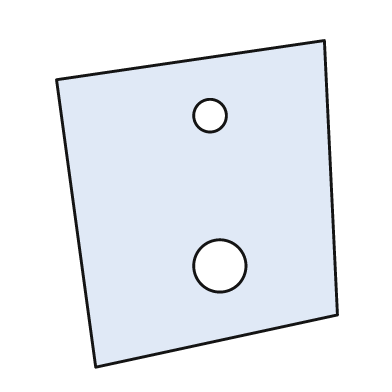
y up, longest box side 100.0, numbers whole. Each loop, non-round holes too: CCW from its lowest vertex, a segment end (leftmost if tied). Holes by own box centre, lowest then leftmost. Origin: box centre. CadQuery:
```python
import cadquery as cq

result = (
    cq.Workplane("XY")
    .moveTo(-31.0, -50.0)
    .lineTo(43.0, -34.0)
    .lineTo(39.0, 50.0)
    .lineTo(-43.0, 38.0)
    .close()
    .moveTo(7.0, -19.0)
    .circle(8.0)
    .moveTo(4.0, 27.0)
    .circle(5.0)
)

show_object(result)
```